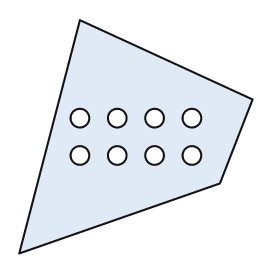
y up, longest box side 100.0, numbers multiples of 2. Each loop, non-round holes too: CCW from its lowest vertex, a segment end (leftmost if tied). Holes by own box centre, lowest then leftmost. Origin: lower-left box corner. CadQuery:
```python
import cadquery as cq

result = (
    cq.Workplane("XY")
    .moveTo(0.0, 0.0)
    .lineTo(86.0, 30.0)
    .lineTo(100.0, 66.0)
    .lineTo(26.0, 100.0)
    .close()
    .moveTo(26.0, 42.0)
    .circle(4.0)
    .moveTo(42.0, 42.0)
    .circle(4.0)
    .moveTo(58.0, 42.0)
    .circle(4.0)
    .moveTo(74.0, 42.0)
    .circle(4.0)
    .moveTo(26.0, 58.0)
    .circle(4.0)
    .moveTo(42.0, 58.0)
    .circle(4.0)
    .moveTo(58.0, 58.0)
    .circle(4.0)
    .moveTo(74.0, 58.0)
    .circle(4.0)
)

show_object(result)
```